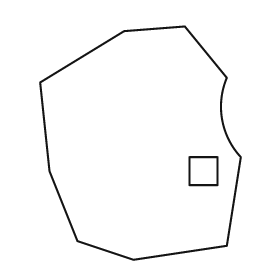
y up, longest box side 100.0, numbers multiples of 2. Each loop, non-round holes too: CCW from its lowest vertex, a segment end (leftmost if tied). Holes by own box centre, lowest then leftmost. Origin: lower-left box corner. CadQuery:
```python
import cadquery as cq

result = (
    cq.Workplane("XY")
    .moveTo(40.0, 0.0)
    .lineTo(80.0, 6.0)
    .lineTo(86.0, 44.0)
    .threePointArc((78.0, 60.0), (80.0, 78.0))
    .lineTo(62.0, 100.0)
    .lineTo(36.0, 98.0)
    .lineTo(0.0, 76.0)
    .lineTo(4.0, 38.0)
    .lineTo(16.0, 8.0)
    .close()
    .moveTo(64.0, 32.0)
    .lineTo(76.0, 32.0)
    .lineTo(76.0, 44.0)
    .lineTo(64.0, 44.0)
    .close()
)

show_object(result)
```